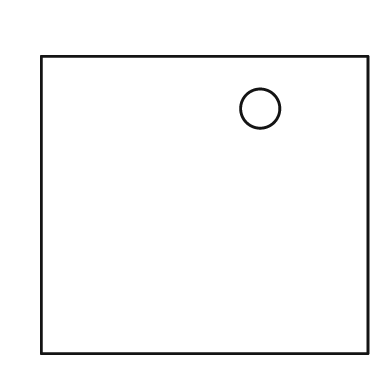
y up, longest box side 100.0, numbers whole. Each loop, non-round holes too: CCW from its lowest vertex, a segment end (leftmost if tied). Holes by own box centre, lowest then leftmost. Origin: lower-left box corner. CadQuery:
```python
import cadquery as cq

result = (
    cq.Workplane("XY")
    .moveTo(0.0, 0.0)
    .lineTo(100.0, 0.0)
    .lineTo(100.0, 91.0)
    .lineTo(0.0, 91.0)
    .close()
    .moveTo(67.0, 75.0)
    .circle(6.0)
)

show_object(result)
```